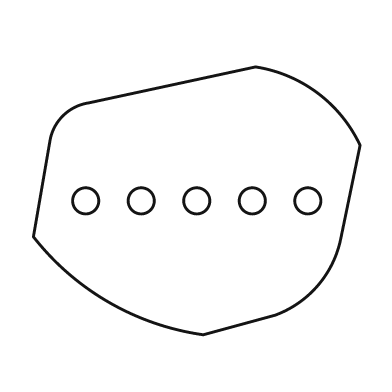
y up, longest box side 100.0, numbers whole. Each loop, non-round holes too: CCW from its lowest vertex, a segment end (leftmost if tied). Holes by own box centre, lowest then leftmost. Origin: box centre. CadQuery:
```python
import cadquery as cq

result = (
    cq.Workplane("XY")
    .moveTo(2.0, -41.0)
    .lineTo(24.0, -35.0)
    .threePointArc((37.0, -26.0), (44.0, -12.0))
    .lineTo(50.0, 17.0)
    .threePointArc((37.0, 33.0), (18.0, 41.0))
    .lineTo(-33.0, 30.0)
    .threePointArc((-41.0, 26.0), (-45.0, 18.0))
    .lineTo(-50.0, -11.0)
    .threePointArc((-27.0, -31.0), (2.0, -41.0))
    .close()
    .moveTo(-34.0, 0.0)
    .circle(4.0)
    .moveTo(-17.0, 0.0)
    .circle(4.0)
    .moveTo(0.0, 0.0)
    .circle(4.0)
    .moveTo(17.0, 0.0)
    .circle(4.0)
    .moveTo(34.0, 0.0)
    .circle(4.0)
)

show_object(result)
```